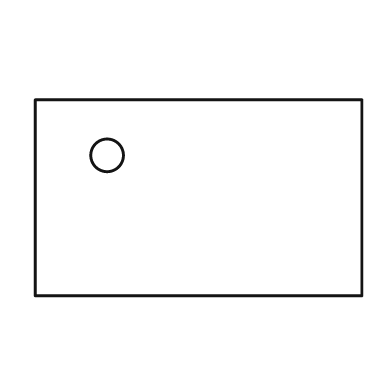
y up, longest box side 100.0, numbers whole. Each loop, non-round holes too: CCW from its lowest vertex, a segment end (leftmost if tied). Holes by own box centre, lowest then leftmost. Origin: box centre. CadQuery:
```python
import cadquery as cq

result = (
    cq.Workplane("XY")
    .moveTo(-50.0, -30.0)
    .lineTo(50.0, -30.0)
    .lineTo(50.0, 30.0)
    .lineTo(-50.0, 30.0)
    .close()
    .moveTo(-28.0, 13.0)
    .circle(5.0)
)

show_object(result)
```